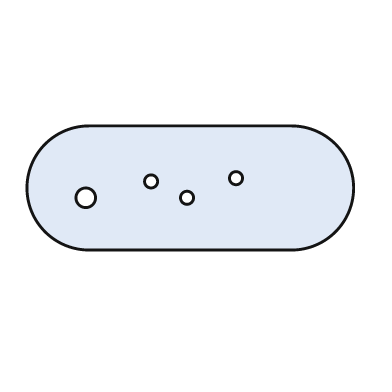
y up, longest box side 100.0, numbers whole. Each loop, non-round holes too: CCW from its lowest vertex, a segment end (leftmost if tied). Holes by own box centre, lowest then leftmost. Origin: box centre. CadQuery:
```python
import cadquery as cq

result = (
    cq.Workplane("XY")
    .moveTo(-31.0, -19.0)
    .lineTo(31.0, -19.0)
    .threePointArc((50.0, 0.0), (31.0, 19.0))
    .lineTo(-31.0, 19.0)
    .threePointArc((-50.0, 0.0), (-31.0, -19.0))
    .close()
    .moveTo(-32.0, -3.0)
    .circle(3.0)
    .moveTo(-1.0, -3.0)
    .circle(2.0)
    .moveTo(-12.0, 2.0)
    .circle(2.0)
    .moveTo(14.0, 3.0)
    .circle(2.0)
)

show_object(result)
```